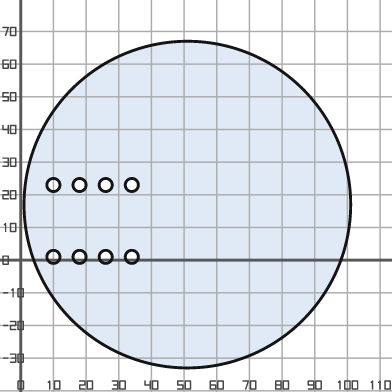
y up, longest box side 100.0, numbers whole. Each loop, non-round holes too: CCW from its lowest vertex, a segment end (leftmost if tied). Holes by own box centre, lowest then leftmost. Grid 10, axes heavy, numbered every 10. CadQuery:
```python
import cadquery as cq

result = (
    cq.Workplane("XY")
    .moveTo(51.0, 17.0)
    .circle(50.0)
    .moveTo(10.0, 1.0)
    .circle(2.0)
    .moveTo(18.0, 1.0)
    .circle(2.0)
    .moveTo(26.0, 1.0)
    .circle(2.0)
    .moveTo(34.0, 1.0)
    .circle(2.0)
    .moveTo(10.0, 23.0)
    .circle(2.0)
    .moveTo(18.0, 23.0)
    .circle(2.0)
    .moveTo(26.0, 23.0)
    .circle(2.0)
    .moveTo(34.0, 23.0)
    .circle(2.0)
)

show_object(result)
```